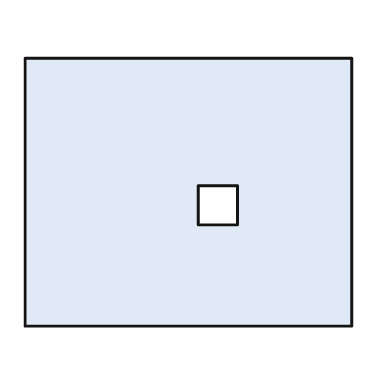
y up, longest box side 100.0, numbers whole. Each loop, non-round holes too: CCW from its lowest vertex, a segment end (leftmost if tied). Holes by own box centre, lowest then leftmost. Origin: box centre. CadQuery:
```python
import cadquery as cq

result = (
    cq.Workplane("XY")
    .moveTo(-50.0, -41.0)
    .lineTo(50.0, -41.0)
    .lineTo(50.0, 41.0)
    .lineTo(-50.0, 41.0)
    .close()
    .moveTo(3.0, -10.0)
    .lineTo(15.0, -10.0)
    .lineTo(15.0, 2.0)
    .lineTo(3.0, 2.0)
    .close()
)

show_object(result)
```